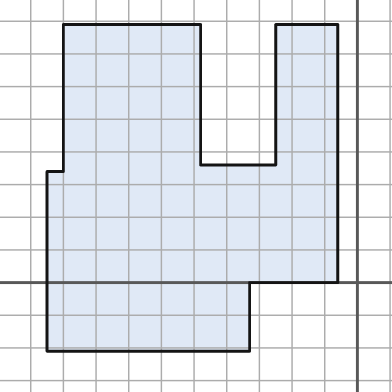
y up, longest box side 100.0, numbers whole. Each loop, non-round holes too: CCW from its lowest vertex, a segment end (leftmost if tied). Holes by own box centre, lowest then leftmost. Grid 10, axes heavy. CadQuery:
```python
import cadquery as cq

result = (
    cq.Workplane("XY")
    .moveTo(-95.0, -21.0)
    .lineTo(-33.0, -21.0)
    .lineTo(-33.0, 0.0)
    .lineTo(-6.0, 0.0)
    .lineTo(-6.0, 79.0)
    .lineTo(-25.0, 79.0)
    .lineTo(-25.0, 36.0)
    .lineTo(-48.0, 36.0)
    .lineTo(-48.0, 79.0)
    .lineTo(-90.0, 79.0)
    .lineTo(-90.0, 34.0)
    .lineTo(-95.0, 34.0)
    .close()
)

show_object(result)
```